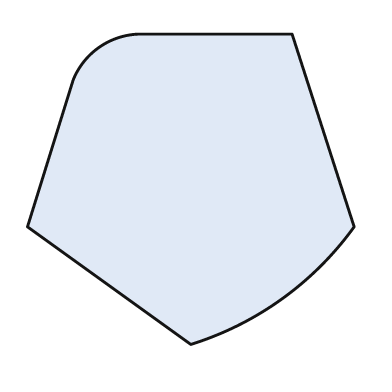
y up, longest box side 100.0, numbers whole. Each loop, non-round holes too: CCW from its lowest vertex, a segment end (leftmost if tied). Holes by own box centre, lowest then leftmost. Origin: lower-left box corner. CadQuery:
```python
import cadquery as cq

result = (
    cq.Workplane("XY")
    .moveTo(50.0, 0.0)
    .threePointArc((78.0, 14.0), (100.0, 36.0))
    .lineTo(81.0, 95.0)
    .lineTo(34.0, 95.0)
    .threePointArc((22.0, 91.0), (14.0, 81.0))
    .lineTo(0.0, 36.0)
    .close()
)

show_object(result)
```